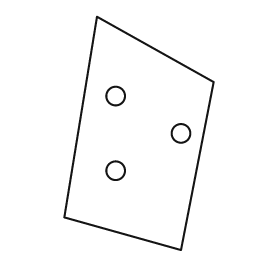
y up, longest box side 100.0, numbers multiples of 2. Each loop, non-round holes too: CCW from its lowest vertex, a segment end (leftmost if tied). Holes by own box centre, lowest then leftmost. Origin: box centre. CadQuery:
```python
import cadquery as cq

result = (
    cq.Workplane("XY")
    .moveTo(18.0, -50.0)
    .lineTo(32.0, 22.0)
    .lineTo(-18.0, 50.0)
    .lineTo(-32.0, -36.0)
    .close()
    .moveTo(-10.0, -16.0)
    .circle(4.0)
    .moveTo(18.0, 0.0)
    .circle(4.0)
    .moveTo(-10.0, 16.0)
    .circle(4.0)
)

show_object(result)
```